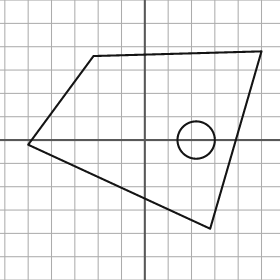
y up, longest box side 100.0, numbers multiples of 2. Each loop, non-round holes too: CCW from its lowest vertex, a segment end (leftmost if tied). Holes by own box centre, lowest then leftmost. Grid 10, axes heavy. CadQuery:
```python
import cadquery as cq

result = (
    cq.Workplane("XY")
    .moveTo(28.0, -38.0)
    .lineTo(50.0, 38.0)
    .lineTo(-22.0, 36.0)
    .lineTo(-50.0, -2.0)
    .close()
    .moveTo(22.0, 0.0)
    .circle(8.0)
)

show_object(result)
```